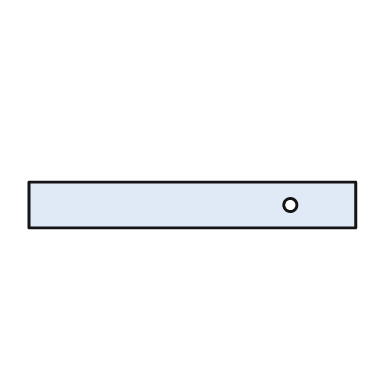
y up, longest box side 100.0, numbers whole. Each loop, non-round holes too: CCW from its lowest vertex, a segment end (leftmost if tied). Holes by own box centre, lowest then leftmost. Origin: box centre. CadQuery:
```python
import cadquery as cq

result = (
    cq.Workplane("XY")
    .moveTo(-50.0, -7.0)
    .lineTo(50.0, -7.0)
    .lineTo(50.0, 7.0)
    .lineTo(-50.0, 7.0)
    .close()
    .moveTo(30.0, 0.0)
    .circle(2.0)
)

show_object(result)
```